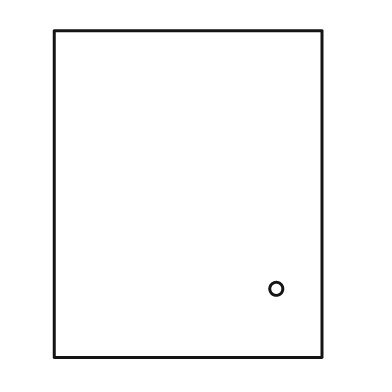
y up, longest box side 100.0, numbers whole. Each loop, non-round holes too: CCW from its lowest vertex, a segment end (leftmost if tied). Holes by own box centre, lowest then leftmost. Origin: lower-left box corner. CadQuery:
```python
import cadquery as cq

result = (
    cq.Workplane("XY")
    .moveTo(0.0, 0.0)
    .lineTo(82.0, 0.0)
    .lineTo(82.0, 100.0)
    .lineTo(0.0, 100.0)
    .close()
    .moveTo(68.0, 21.0)
    .circle(2.0)
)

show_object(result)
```